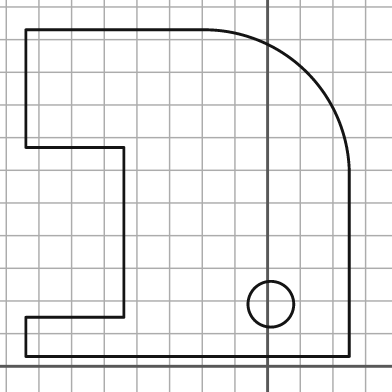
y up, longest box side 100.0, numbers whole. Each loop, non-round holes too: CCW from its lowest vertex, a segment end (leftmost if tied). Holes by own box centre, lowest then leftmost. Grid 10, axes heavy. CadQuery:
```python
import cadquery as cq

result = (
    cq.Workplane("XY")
    .moveTo(-74.0, 3.0)
    .lineTo(25.0, 3.0)
    .lineTo(25.0, 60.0)
    .threePointArc((12.0, 90.0), (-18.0, 103.0))
    .lineTo(-74.0, 103.0)
    .lineTo(-74.0, 67.0)
    .lineTo(-44.0, 67.0)
    .lineTo(-44.0, 15.0)
    .lineTo(-74.0, 15.0)
    .close()
    .moveTo(1.0, 19.0)
    .circle(7.0)
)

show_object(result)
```